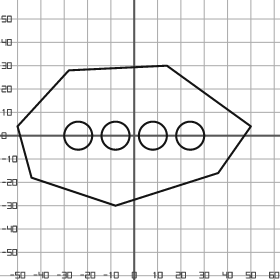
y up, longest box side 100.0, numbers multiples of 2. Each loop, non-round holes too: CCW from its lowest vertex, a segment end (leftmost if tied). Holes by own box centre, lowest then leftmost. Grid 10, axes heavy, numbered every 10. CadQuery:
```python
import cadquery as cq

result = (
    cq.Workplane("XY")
    .moveTo(-8.0, -30.0)
    .lineTo(36.0, -16.0)
    .lineTo(50.0, 4.0)
    .lineTo(14.0, 30.0)
    .lineTo(-28.0, 28.0)
    .lineTo(-50.0, 4.0)
    .lineTo(-44.0, -18.0)
    .close()
    .moveTo(-24.0, 0.0)
    .circle(6.0)
    .moveTo(-8.0, 0.0)
    .circle(6.0)
    .moveTo(8.0, 0.0)
    .circle(6.0)
    .moveTo(24.0, 0.0)
    .circle(6.0)
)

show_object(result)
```